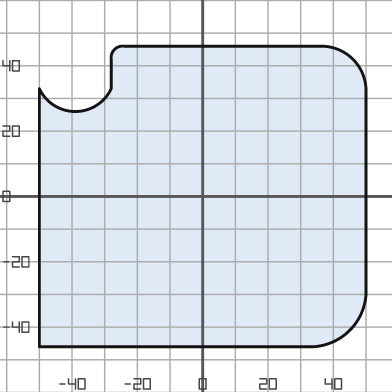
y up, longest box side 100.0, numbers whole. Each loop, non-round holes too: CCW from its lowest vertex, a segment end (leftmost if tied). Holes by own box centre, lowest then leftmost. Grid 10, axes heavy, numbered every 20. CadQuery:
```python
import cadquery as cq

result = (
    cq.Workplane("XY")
    .moveTo(-50.0, -46.0)
    .lineTo(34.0, -46.0)
    .threePointArc((45.0, -41.0), (50.0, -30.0))
    .lineTo(50.0, 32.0)
    .threePointArc((46.0, 42.0), (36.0, 46.0))
    .lineTo(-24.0, 46.0)
    .threePointArc((-27.0, 45.0), (-28.0, 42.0))
    .lineTo(-28.0, 33.0)
    .threePointArc((-39.0, 26.0), (-50.0, 33.0))
    .close()
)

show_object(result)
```